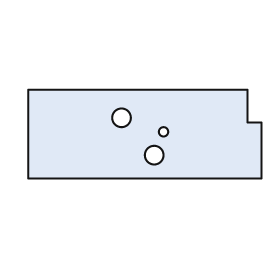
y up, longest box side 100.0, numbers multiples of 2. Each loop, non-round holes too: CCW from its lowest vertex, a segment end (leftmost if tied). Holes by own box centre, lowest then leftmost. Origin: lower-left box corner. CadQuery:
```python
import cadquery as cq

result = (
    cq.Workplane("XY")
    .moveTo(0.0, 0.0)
    .lineTo(100.0, 0.0)
    .lineTo(100.0, 24.0)
    .lineTo(94.0, 24.0)
    .lineTo(94.0, 38.0)
    .lineTo(0.0, 38.0)
    .close()
    .moveTo(54.0, 10.0)
    .circle(4.0)
    .moveTo(58.0, 20.0)
    .circle(2.0)
    .moveTo(40.0, 26.0)
    .circle(4.0)
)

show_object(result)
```